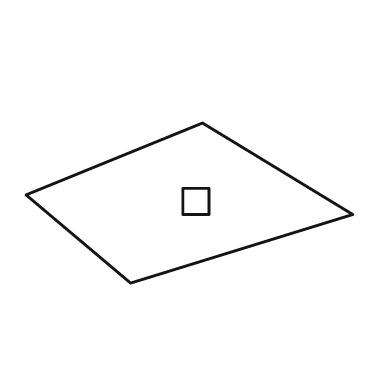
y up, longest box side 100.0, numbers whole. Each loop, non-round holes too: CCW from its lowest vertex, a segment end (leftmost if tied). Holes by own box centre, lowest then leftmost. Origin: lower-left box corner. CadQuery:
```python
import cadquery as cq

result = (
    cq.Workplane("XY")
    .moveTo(32.0, 0.0)
    .lineTo(100.0, 21.0)
    .lineTo(54.0, 49.0)
    .lineTo(0.0, 27.0)
    .close()
    .moveTo(48.0, 21.0)
    .lineTo(56.0, 21.0)
    .lineTo(56.0, 29.0)
    .lineTo(48.0, 29.0)
    .close()
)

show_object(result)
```